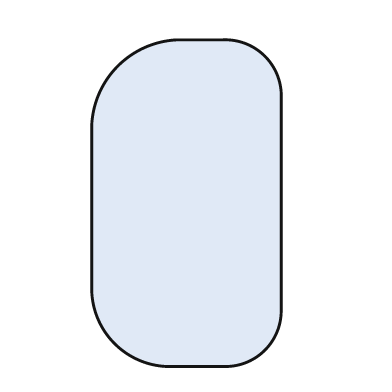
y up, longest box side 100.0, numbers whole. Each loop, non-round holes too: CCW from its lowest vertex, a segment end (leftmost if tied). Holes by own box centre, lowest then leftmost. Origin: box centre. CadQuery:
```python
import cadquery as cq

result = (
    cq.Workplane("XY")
    .moveTo(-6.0, -50.0)
    .lineTo(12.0, -50.0)
    .threePointArc((24.0, -45.0), (29.0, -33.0))
    .lineTo(29.0, 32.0)
    .threePointArc((24.0, 45.0), (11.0, 50.0))
    .lineTo(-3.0, 50.0)
    .threePointArc((-21.0, 42.0), (-29.0, 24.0))
    .lineTo(-29.0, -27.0)
    .threePointArc((-22.0, -43.0), (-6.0, -50.0))
    .close()
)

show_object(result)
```